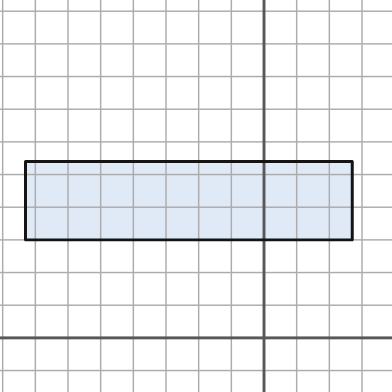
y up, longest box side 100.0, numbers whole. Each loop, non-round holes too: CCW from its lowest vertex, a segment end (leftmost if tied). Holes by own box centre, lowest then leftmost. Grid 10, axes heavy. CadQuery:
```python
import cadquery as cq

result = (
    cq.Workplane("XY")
    .moveTo(-73.0, 30.0)
    .lineTo(27.0, 30.0)
    .lineTo(27.0, 54.0)
    .lineTo(-73.0, 54.0)
    .close()
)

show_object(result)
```